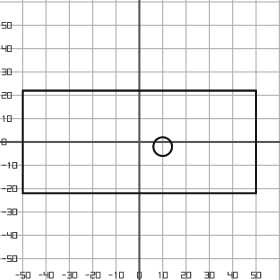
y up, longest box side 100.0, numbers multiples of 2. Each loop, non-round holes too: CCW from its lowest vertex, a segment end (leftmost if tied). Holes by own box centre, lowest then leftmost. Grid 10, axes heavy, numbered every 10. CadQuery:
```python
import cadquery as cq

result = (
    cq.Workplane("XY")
    .moveTo(-50.0, -22.0)
    .lineTo(50.0, -22.0)
    .lineTo(50.0, 22.0)
    .lineTo(-50.0, 22.0)
    .close()
    .moveTo(10.0, -2.0)
    .circle(4.0)
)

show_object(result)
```